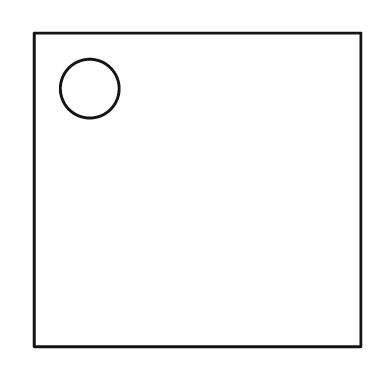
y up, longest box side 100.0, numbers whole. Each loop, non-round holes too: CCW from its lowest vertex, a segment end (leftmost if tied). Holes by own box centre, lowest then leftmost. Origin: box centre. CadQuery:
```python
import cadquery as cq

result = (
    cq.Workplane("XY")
    .moveTo(-50.0, -48.0)
    .lineTo(50.0, -48.0)
    .lineTo(50.0, 48.0)
    .lineTo(-50.0, 48.0)
    .close()
    .moveTo(-33.0, 31.0)
    .circle(9.0)
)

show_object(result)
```